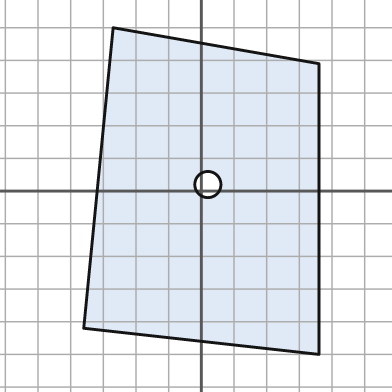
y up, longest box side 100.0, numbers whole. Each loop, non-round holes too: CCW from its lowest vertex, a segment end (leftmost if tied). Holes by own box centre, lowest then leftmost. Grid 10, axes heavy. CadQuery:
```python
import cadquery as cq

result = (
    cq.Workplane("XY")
    .moveTo(36.0, -50.0)
    .lineTo(36.0, 39.0)
    .lineTo(-27.0, 50.0)
    .lineTo(-36.0, -42.0)
    .close()
    .moveTo(2.0, 2.0)
    .circle(4.0)
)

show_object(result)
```